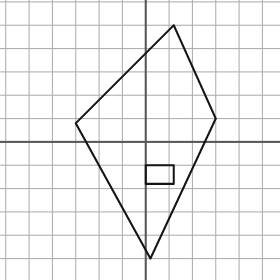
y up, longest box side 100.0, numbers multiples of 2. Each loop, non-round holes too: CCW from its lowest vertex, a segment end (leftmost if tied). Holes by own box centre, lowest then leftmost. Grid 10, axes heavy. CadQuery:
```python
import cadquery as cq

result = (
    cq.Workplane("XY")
    .moveTo(2.0, -50.0)
    .lineTo(30.0, 10.0)
    .lineTo(12.0, 50.0)
    .lineTo(-30.0, 8.0)
    .close()
    .moveTo(0.0, -18.0)
    .lineTo(12.0, -18.0)
    .lineTo(12.0, -10.0)
    .lineTo(0.0, -10.0)
    .close()
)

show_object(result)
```